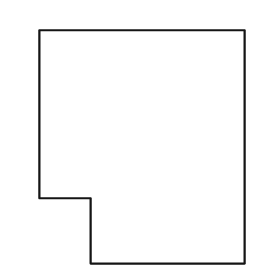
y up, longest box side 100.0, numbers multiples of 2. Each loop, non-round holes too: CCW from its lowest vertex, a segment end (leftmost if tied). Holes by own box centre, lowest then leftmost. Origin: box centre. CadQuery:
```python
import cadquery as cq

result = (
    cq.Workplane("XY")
    .moveTo(-22.0, -50.0)
    .lineTo(44.0, -50.0)
    .lineTo(44.0, 50.0)
    .lineTo(-44.0, 50.0)
    .lineTo(-44.0, -22.0)
    .lineTo(-22.0, -22.0)
    .close()
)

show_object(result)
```